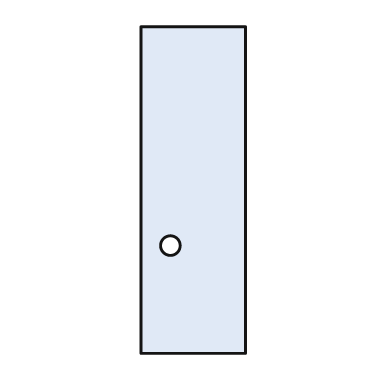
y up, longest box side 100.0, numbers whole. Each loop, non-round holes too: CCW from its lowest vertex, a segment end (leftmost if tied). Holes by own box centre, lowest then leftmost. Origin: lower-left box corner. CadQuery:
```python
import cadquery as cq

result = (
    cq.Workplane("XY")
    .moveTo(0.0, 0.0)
    .lineTo(32.0, 0.0)
    .lineTo(32.0, 100.0)
    .lineTo(0.0, 100.0)
    .close()
    .moveTo(9.0, 33.0)
    .circle(3.0)
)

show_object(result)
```